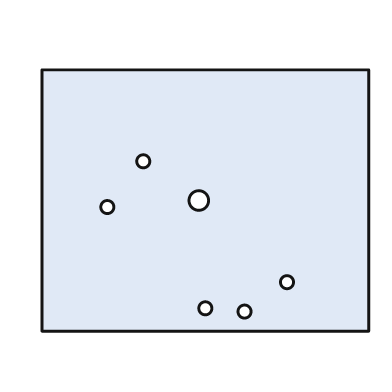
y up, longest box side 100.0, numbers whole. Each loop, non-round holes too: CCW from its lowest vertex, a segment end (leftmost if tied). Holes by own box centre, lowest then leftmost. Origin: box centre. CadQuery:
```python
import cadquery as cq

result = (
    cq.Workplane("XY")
    .moveTo(-50.0, -40.0)
    .lineTo(50.0, -40.0)
    .lineTo(50.0, 40.0)
    .lineTo(-50.0, 40.0)
    .close()
    .moveTo(12.0, -34.0)
    .circle(2.0)
    .moveTo(0.0, -33.0)
    .circle(2.0)
    .moveTo(25.0, -25.0)
    .circle(2.0)
    .moveTo(-30.0, -2.0)
    .circle(2.0)
    .moveTo(-2.0, 0.0)
    .circle(3.0)
    .moveTo(-19.0, 12.0)
    .circle(2.0)
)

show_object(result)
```